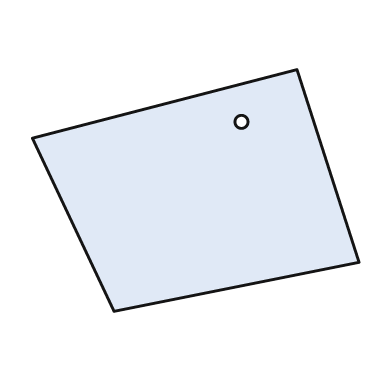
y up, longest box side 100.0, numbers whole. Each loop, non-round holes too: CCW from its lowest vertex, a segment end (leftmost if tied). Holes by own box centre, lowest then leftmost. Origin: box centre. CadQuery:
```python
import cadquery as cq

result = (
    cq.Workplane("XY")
    .moveTo(-25.0, -37.0)
    .lineTo(50.0, -22.0)
    .lineTo(31.0, 37.0)
    .lineTo(-50.0, 16.0)
    .close()
    .moveTo(14.0, 21.0)
    .circle(2.0)
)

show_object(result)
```